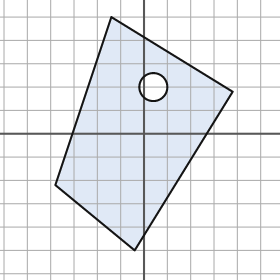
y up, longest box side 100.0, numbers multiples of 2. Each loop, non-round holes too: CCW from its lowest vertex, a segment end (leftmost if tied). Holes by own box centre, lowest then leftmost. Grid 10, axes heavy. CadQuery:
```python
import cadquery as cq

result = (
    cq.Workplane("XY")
    .moveTo(-4.0, -50.0)
    .lineTo(38.0, 18.0)
    .lineTo(-14.0, 50.0)
    .lineTo(-38.0, -22.0)
    .close()
    .moveTo(4.0, 20.0)
    .circle(6.0)
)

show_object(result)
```